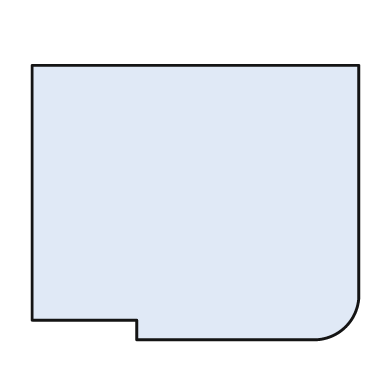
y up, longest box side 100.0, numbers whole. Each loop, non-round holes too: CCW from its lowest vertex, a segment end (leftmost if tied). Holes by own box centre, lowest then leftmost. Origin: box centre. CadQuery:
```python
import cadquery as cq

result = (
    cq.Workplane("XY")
    .moveTo(-18.0, -42.0)
    .lineTo(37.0, -42.0)
    .threePointArc((46.0, -38.0), (50.0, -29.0))
    .lineTo(50.0, 42.0)
    .lineTo(-50.0, 42.0)
    .lineTo(-50.0, -36.0)
    .lineTo(-18.0, -36.0)
    .close()
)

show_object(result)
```